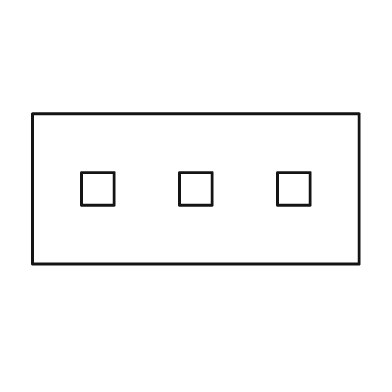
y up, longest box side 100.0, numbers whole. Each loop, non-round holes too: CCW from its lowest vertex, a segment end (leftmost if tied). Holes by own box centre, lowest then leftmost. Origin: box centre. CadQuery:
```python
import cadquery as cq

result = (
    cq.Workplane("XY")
    .moveTo(-50.0, -23.0)
    .lineTo(50.0, -23.0)
    .lineTo(50.0, 23.0)
    .lineTo(-50.0, 23.0)
    .close()
    .moveTo(-35.0, -5.0)
    .lineTo(-25.0, -5.0)
    .lineTo(-25.0, 5.0)
    .lineTo(-35.0, 5.0)
    .close()
    .moveTo(-5.0, -5.0)
    .lineTo(5.0, -5.0)
    .lineTo(5.0, 5.0)
    .lineTo(-5.0, 5.0)
    .close()
    .moveTo(25.0, -5.0)
    .lineTo(35.0, -5.0)
    .lineTo(35.0, 5.0)
    .lineTo(25.0, 5.0)
    .close()
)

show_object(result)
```